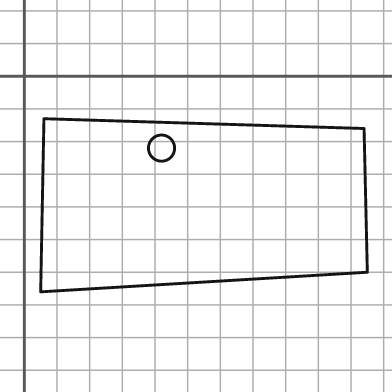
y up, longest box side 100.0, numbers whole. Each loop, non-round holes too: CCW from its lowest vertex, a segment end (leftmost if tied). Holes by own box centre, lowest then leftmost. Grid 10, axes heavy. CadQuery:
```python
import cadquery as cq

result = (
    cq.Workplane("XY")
    .moveTo(5.0, -66.0)
    .lineTo(105.0, -60.0)
    .lineTo(104.0, -16.0)
    .lineTo(6.0, -13.0)
    .close()
    .moveTo(42.0, -22.0)
    .circle(4.0)
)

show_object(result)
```